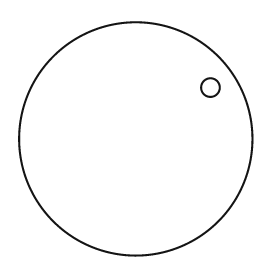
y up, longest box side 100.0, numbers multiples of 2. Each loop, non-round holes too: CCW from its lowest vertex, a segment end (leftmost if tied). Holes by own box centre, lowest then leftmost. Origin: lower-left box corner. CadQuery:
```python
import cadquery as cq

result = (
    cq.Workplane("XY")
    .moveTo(50.0, 50.0)
    .circle(50.0)
    .moveTo(82.0, 72.0)
    .circle(4.0)
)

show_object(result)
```